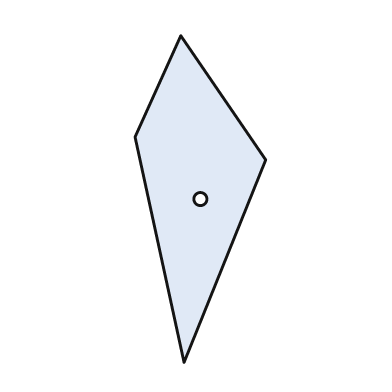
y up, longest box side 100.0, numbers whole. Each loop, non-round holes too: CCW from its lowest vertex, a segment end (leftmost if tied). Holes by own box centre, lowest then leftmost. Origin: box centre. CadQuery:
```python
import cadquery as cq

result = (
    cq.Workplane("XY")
    .moveTo(-5.0, -50.0)
    .lineTo(20.0, 12.0)
    .lineTo(-6.0, 50.0)
    .lineTo(-20.0, 19.0)
    .close()
    .moveTo(0.0, 0.0)
    .circle(2.0)
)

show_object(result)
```